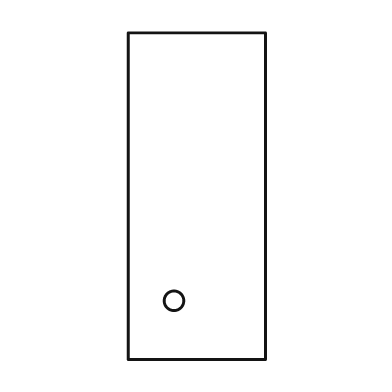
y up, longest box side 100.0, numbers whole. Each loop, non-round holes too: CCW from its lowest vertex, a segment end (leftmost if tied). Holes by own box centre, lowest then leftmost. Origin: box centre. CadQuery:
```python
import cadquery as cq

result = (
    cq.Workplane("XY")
    .moveTo(-21.0, -50.0)
    .lineTo(21.0, -50.0)
    .lineTo(21.0, 50.0)
    .lineTo(-21.0, 50.0)
    .close()
    .moveTo(-7.0, -32.0)
    .circle(3.0)
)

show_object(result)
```